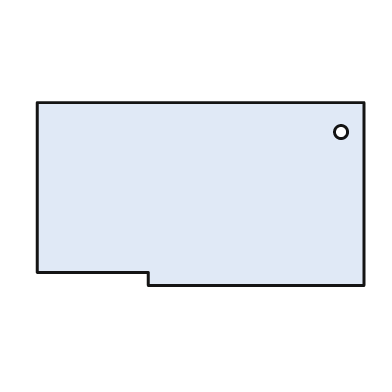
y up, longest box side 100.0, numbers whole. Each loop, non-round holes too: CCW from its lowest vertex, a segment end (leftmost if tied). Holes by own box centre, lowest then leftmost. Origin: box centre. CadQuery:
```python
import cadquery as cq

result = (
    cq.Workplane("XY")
    .moveTo(-16.0, -28.0)
    .lineTo(50.0, -28.0)
    .lineTo(50.0, 28.0)
    .lineTo(-50.0, 28.0)
    .lineTo(-50.0, -24.0)
    .lineTo(-16.0, -24.0)
    .close()
    .moveTo(43.0, 19.0)
    .circle(2.0)
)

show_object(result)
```